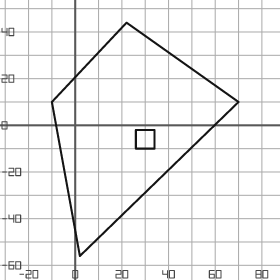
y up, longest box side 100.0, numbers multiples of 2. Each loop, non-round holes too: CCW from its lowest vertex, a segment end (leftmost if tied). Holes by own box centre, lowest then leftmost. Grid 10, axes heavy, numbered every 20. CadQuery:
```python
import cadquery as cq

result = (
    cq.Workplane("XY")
    .moveTo(2.0, -56.0)
    .lineTo(70.0, 10.0)
    .lineTo(22.0, 44.0)
    .lineTo(-10.0, 10.0)
    .close()
    .moveTo(26.0, -10.0)
    .lineTo(34.0, -10.0)
    .lineTo(34.0, -2.0)
    .lineTo(26.0, -2.0)
    .close()
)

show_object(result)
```